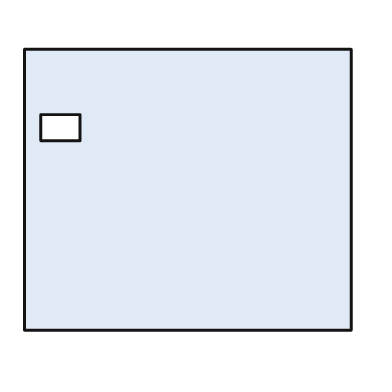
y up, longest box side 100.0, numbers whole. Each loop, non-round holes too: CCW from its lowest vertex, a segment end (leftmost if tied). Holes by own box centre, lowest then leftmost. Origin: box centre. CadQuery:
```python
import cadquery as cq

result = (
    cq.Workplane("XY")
    .moveTo(-50.0, -43.0)
    .lineTo(50.0, -43.0)
    .lineTo(50.0, 43.0)
    .lineTo(-50.0, 43.0)
    .close()
    .moveTo(-45.0, 15.0)
    .lineTo(-33.0, 15.0)
    .lineTo(-33.0, 23.0)
    .lineTo(-45.0, 23.0)
    .close()
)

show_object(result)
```